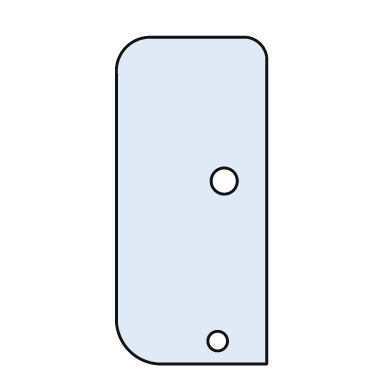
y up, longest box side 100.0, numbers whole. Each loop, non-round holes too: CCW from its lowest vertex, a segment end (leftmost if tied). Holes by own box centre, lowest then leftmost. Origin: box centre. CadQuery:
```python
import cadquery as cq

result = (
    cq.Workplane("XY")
    .moveTo(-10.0, -50.0)
    .lineTo(23.0, -50.0)
    .lineTo(23.0, 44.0)
    .threePointArc((21.0, 48.0), (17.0, 50.0))
    .lineTo(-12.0, 50.0)
    .threePointArc((-20.0, 47.0), (-23.0, 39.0))
    .lineTo(-23.0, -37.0)
    .threePointArc((-19.0, -46.0), (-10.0, -50.0))
    .close()
    .moveTo(8.0, -43.0)
    .circle(3.0)
    .moveTo(10.0, 6.0)
    .circle(4.0)
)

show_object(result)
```